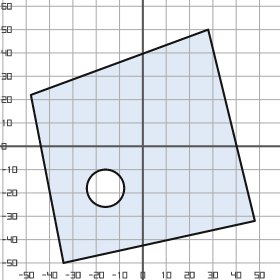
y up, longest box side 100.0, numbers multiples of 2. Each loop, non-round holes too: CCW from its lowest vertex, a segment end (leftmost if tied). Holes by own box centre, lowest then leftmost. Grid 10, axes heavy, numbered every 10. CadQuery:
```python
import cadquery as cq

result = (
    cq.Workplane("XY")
    .moveTo(-34.0, -50.0)
    .lineTo(48.0, -32.0)
    .lineTo(28.0, 50.0)
    .lineTo(-48.0, 22.0)
    .close()
    .moveTo(-16.0, -18.0)
    .circle(8.0)
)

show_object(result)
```